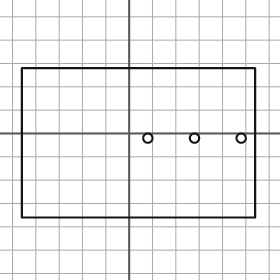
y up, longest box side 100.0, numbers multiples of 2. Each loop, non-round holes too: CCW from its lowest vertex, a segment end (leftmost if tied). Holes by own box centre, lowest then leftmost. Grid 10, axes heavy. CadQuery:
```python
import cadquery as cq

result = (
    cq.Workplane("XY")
    .moveTo(-46.0, -36.0)
    .lineTo(54.0, -36.0)
    .lineTo(54.0, 28.0)
    .lineTo(-46.0, 28.0)
    .close()
    .moveTo(8.0, -2.0)
    .circle(2.0)
    .moveTo(28.0, -2.0)
    .circle(2.0)
    .moveTo(48.0, -2.0)
    .circle(2.0)
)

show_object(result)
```